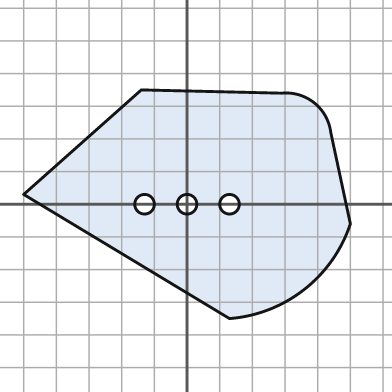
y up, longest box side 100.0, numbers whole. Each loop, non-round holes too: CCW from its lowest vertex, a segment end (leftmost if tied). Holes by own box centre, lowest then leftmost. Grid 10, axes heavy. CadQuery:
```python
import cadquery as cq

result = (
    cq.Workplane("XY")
    .moveTo(13.0, -35.0)
    .threePointArc((36.0, -26.0), (50.0, -6.0))
    .lineTo(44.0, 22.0)
    .threePointArc((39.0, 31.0), (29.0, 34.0))
    .lineTo(-14.0, 35.0)
    .lineTo(-50.0, 3.0)
    .close()
    .moveTo(-13.0, 0.0)
    .circle(3.0)
    .moveTo(0.0, 0.0)
    .circle(3.0)
    .moveTo(13.0, 0.0)
    .circle(3.0)
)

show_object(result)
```